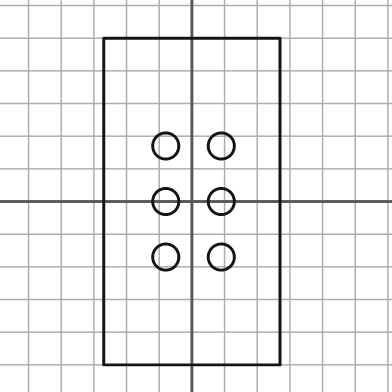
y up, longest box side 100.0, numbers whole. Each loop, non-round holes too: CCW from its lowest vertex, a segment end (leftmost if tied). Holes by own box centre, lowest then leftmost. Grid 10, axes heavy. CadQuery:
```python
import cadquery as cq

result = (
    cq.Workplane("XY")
    .moveTo(-27.0, -50.0)
    .lineTo(27.0, -50.0)
    .lineTo(27.0, 50.0)
    .lineTo(-27.0, 50.0)
    .close()
    .moveTo(-8.0, -17.0)
    .circle(4.0)
    .moveTo(9.0, -17.0)
    .circle(4.0)
    .moveTo(-8.0, 0.0)
    .circle(4.0)
    .moveTo(9.0, 0.0)
    .circle(4.0)
    .moveTo(-8.0, 17.0)
    .circle(4.0)
    .moveTo(9.0, 17.0)
    .circle(4.0)
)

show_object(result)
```